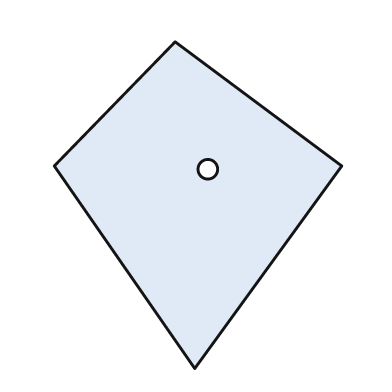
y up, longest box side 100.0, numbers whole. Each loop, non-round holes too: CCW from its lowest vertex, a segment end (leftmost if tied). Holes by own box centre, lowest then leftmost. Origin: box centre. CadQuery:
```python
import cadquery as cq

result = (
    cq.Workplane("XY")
    .moveTo(-1.0, -50.0)
    .lineTo(44.0, 12.0)
    .lineTo(-7.0, 50.0)
    .lineTo(-44.0, 12.0)
    .close()
    .moveTo(3.0, 11.0)
    .circle(3.0)
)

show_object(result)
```